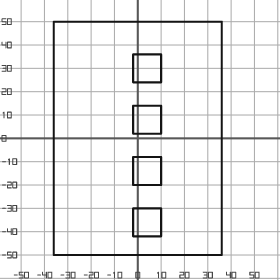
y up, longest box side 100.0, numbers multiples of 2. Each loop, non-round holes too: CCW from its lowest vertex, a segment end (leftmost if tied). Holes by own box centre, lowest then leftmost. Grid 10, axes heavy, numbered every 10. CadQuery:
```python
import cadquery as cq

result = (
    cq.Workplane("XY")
    .moveTo(-36.0, -50.0)
    .lineTo(36.0, -50.0)
    .lineTo(36.0, 50.0)
    .lineTo(-36.0, 50.0)
    .close()
    .moveTo(-2.0, -42.0)
    .lineTo(10.0, -42.0)
    .lineTo(10.0, -30.0)
    .lineTo(-2.0, -30.0)
    .close()
    .moveTo(-2.0, -20.0)
    .lineTo(10.0, -20.0)
    .lineTo(10.0, -8.0)
    .lineTo(-2.0, -8.0)
    .close()
    .moveTo(-2.0, 2.0)
    .lineTo(10.0, 2.0)
    .lineTo(10.0, 14.0)
    .lineTo(-2.0, 14.0)
    .close()
    .moveTo(-2.0, 24.0)
    .lineTo(10.0, 24.0)
    .lineTo(10.0, 36.0)
    .lineTo(-2.0, 36.0)
    .close()
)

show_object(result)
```